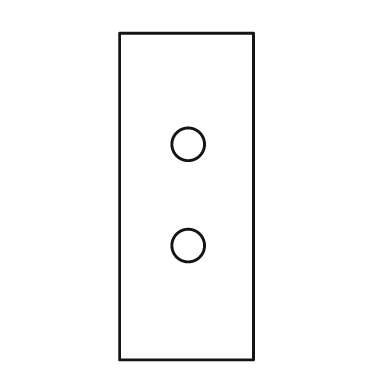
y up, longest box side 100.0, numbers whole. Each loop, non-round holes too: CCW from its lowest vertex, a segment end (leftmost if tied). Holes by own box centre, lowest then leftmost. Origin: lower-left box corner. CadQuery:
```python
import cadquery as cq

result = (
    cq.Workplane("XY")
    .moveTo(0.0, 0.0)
    .lineTo(41.0, 0.0)
    .lineTo(41.0, 100.0)
    .lineTo(0.0, 100.0)
    .close()
    .moveTo(21.0, 35.0)
    .circle(5.0)
    .moveTo(21.0, 66.0)
    .circle(5.0)
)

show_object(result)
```